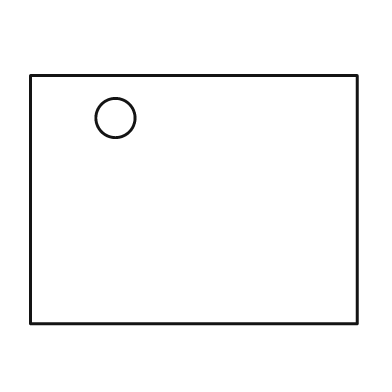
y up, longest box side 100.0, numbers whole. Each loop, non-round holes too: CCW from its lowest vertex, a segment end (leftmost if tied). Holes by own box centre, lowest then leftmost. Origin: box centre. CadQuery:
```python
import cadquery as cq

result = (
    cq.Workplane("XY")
    .moveTo(-50.0, -38.0)
    .lineTo(50.0, -38.0)
    .lineTo(50.0, 38.0)
    .lineTo(-50.0, 38.0)
    .close()
    .moveTo(-24.0, 25.0)
    .circle(6.0)
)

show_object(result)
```